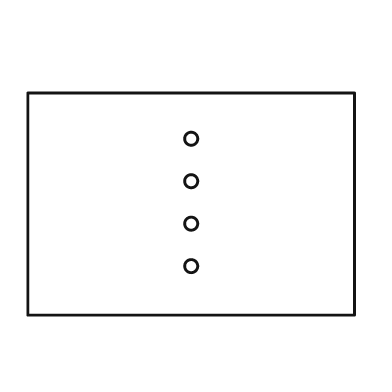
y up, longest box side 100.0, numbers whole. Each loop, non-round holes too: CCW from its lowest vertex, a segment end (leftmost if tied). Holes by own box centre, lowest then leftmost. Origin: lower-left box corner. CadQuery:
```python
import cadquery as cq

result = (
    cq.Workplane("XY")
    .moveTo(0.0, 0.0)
    .lineTo(100.0, 0.0)
    .lineTo(100.0, 68.0)
    .lineTo(0.0, 68.0)
    .close()
    .moveTo(50.0, 15.0)
    .circle(2.0)
    .moveTo(50.0, 28.0)
    .circle(2.0)
    .moveTo(50.0, 41.0)
    .circle(2.0)
    .moveTo(50.0, 54.0)
    .circle(2.0)
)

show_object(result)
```